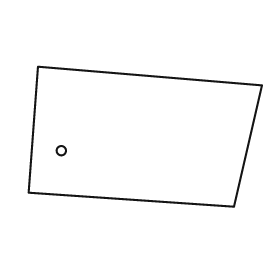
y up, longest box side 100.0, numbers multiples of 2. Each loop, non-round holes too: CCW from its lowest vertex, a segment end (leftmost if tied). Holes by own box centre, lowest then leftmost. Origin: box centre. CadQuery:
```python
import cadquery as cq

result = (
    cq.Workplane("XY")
    .moveTo(38.0, -30.0)
    .lineTo(50.0, 22.0)
    .lineTo(-46.0, 30.0)
    .lineTo(-50.0, -24.0)
    .close()
    .moveTo(-36.0, -6.0)
    .circle(2.0)
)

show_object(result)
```